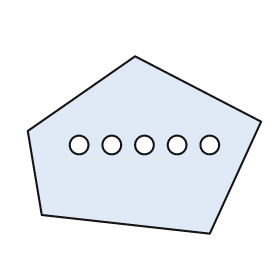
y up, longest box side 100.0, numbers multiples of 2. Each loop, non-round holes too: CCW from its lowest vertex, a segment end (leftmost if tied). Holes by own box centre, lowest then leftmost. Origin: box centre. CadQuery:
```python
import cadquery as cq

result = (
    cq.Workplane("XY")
    .moveTo(28.0, -38.0)
    .lineTo(50.0, 10.0)
    .lineTo(-4.0, 38.0)
    .lineTo(-50.0, 6.0)
    .lineTo(-44.0, -30.0)
    .close()
    .moveTo(-28.0, 0.0)
    .circle(4.0)
    .moveTo(-14.0, 0.0)
    .circle(4.0)
    .moveTo(0.0, 0.0)
    .circle(4.0)
    .moveTo(14.0, 0.0)
    .circle(4.0)
    .moveTo(28.0, 0.0)
    .circle(4.0)
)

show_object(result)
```